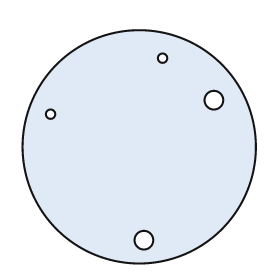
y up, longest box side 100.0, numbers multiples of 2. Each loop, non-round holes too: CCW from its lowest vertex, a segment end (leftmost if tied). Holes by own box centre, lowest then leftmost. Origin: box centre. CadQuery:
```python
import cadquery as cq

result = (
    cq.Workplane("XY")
    .moveTo(0.0, 0.0)
    .circle(50.0)
    .moveTo(2.0, -40.0)
    .circle(4.0)
    .moveTo(-38.0, 14.0)
    .circle(2.0)
    .moveTo(32.0, 20.0)
    .circle(4.0)
    .moveTo(10.0, 38.0)
    .circle(2.0)
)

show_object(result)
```